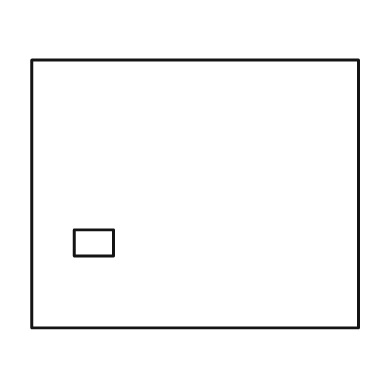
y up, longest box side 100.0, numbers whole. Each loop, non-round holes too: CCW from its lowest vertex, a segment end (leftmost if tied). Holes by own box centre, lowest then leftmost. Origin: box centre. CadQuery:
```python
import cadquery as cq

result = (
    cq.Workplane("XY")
    .moveTo(-50.0, -41.0)
    .lineTo(50.0, -41.0)
    .lineTo(50.0, 41.0)
    .lineTo(-50.0, 41.0)
    .close()
    .moveTo(-37.0, -19.0)
    .lineTo(-25.0, -19.0)
    .lineTo(-25.0, -11.0)
    .lineTo(-37.0, -11.0)
    .close()
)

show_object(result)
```